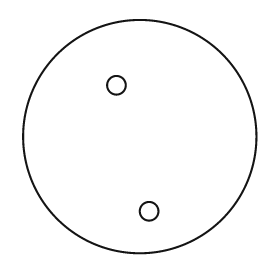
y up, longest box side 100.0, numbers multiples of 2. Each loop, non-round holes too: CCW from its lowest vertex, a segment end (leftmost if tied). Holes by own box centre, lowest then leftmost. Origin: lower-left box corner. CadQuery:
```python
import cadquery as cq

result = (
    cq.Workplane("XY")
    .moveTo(50.0, 50.0)
    .circle(50.0)
    .moveTo(54.0, 18.0)
    .circle(4.0)
    .moveTo(40.0, 72.0)
    .circle(4.0)
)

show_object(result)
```